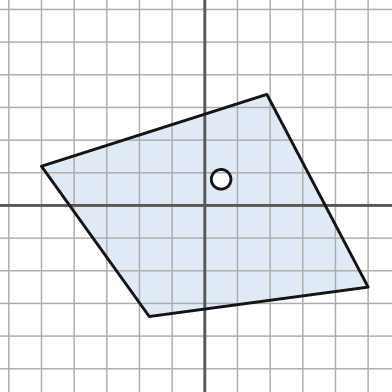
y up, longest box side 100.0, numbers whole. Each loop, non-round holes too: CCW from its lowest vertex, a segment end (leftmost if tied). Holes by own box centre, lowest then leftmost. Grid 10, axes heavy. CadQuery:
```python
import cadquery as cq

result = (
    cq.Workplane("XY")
    .moveTo(-17.0, -34.0)
    .lineTo(50.0, -25.0)
    .lineTo(19.0, 34.0)
    .lineTo(-50.0, 12.0)
    .close()
    .moveTo(5.0, 8.0)
    .circle(3.0)
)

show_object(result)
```